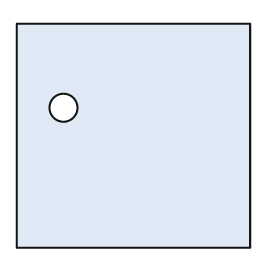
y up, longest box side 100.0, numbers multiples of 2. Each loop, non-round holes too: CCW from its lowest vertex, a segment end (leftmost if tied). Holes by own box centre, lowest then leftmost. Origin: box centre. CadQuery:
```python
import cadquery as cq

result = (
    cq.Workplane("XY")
    .moveTo(-50.0, -48.0)
    .lineTo(50.0, -48.0)
    .lineTo(50.0, 48.0)
    .lineTo(-50.0, 48.0)
    .close()
    .moveTo(-30.0, 12.0)
    .circle(6.0)
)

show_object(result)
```